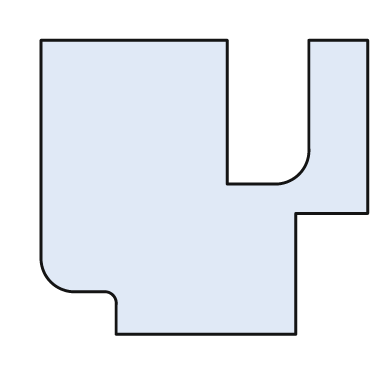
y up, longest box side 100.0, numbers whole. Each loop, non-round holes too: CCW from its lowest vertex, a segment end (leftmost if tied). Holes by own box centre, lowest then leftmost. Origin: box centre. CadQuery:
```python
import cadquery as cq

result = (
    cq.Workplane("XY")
    .moveTo(-27.0, -45.0)
    .lineTo(28.0, -45.0)
    .lineTo(28.0, -8.0)
    .lineTo(50.0, -8.0)
    .lineTo(50.0, 45.0)
    .lineTo(32.0, 45.0)
    .lineTo(32.0, 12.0)
    .threePointArc((29.0, 4.0), (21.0, 1.0))
    .lineTo(7.0, 1.0)
    .lineTo(7.0, 45.0)
    .lineTo(-50.0, 45.0)
    .lineTo(-50.0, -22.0)
    .threePointArc((-47.0, -29.0), (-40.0, -32.0))
    .lineTo(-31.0, -32.0)
    .threePointArc((-28.0, -33.0), (-27.0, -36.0))
    .close()
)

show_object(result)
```